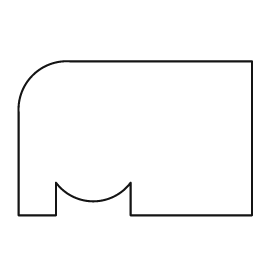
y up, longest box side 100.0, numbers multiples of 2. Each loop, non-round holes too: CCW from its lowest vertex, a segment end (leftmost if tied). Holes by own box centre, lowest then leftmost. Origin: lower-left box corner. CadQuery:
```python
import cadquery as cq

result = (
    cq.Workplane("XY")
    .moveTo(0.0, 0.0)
    .lineTo(16.0, 0.0)
    .lineTo(16.0, 14.0)
    .threePointArc((32.0, 6.0), (48.0, 14.0))
    .lineTo(48.0, 0.0)
    .lineTo(100.0, 0.0)
    .lineTo(100.0, 66.0)
    .lineTo(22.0, 66.0)
    .threePointArc((6.0, 60.0), (0.0, 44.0))
    .close()
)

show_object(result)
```